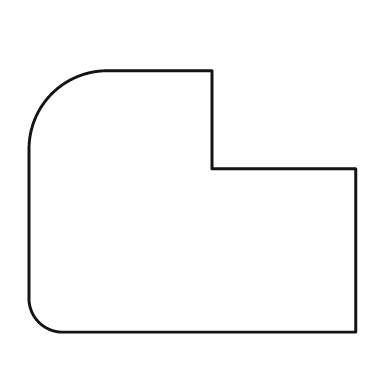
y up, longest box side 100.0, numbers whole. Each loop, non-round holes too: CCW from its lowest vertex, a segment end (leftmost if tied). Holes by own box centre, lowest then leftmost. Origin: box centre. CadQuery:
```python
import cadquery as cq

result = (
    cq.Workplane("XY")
    .moveTo(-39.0, -40.0)
    .lineTo(50.0, -40.0)
    .lineTo(50.0, 10.0)
    .lineTo(6.0, 10.0)
    .lineTo(6.0, 40.0)
    .lineTo(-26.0, 40.0)
    .threePointArc((-43.0, 33.0), (-50.0, 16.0))
    .lineTo(-50.0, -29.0)
    .threePointArc((-47.0, -37.0), (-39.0, -40.0))
    .close()
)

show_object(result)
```